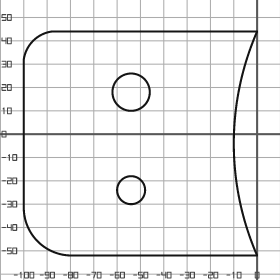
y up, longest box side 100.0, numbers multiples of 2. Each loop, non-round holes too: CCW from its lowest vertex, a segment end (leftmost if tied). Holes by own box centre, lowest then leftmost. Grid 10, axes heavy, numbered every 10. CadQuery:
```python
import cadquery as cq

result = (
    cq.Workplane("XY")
    .moveTo(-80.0, -52.0)
    .lineTo(0.0, -52.0)
    .threePointArc((-10.0, -4.0), (0.0, 44.0))
    .lineTo(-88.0, 44.0)
    .threePointArc((-96.0, 40.0), (-100.0, 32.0))
    .lineTo(-100.0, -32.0)
    .threePointArc((-94.0, -46.0), (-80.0, -52.0))
    .close()
    .moveTo(-54.0, -24.0)
    .circle(6.0)
    .moveTo(-54.0, 18.0)
    .circle(8.0)
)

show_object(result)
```